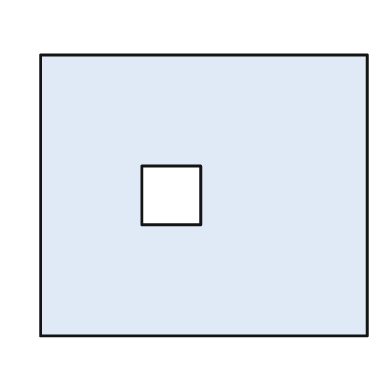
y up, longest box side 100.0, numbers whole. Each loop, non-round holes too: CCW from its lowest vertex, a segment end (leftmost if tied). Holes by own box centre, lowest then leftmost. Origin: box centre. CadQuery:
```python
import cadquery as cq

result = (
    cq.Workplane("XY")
    .moveTo(-50.0, -43.0)
    .lineTo(50.0, -43.0)
    .lineTo(50.0, 43.0)
    .lineTo(-50.0, 43.0)
    .close()
    .moveTo(-19.0, -9.0)
    .lineTo(-1.0, -9.0)
    .lineTo(-1.0, 9.0)
    .lineTo(-19.0, 9.0)
    .close()
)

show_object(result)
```